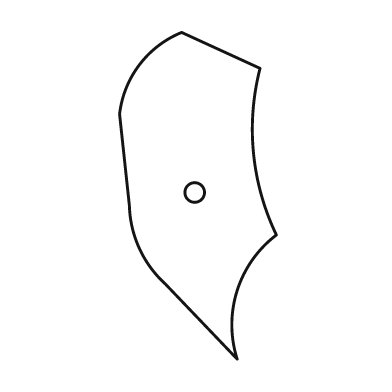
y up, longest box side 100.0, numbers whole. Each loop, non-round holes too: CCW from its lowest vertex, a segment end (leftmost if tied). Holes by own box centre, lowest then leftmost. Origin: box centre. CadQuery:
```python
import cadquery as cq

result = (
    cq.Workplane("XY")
    .moveTo(12.0, -50.0)
    .threePointArc((12.0, -29.0), (24.0, -12.0))
    .threePointArc((17.0, 13.0), (19.0, 39.0))
    .lineTo(-5.0, 50.0)
    .threePointArc((-18.0, 40.0), (-24.0, 25.0))
    .lineTo(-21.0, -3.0)
    .threePointArc((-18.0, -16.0), (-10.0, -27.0))
    .close()
    .moveTo(-1.0, 1.0)
    .circle(3.0)
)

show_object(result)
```